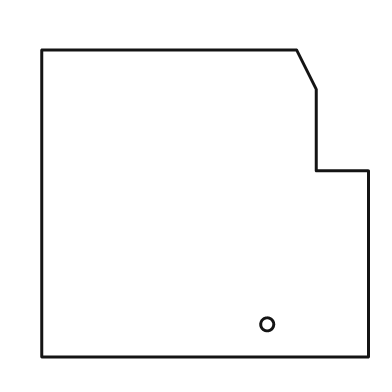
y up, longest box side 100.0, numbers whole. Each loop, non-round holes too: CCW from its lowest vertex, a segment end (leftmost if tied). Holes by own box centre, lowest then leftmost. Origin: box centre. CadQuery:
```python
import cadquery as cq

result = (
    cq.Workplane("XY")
    .moveTo(-50.0, -47.0)
    .lineTo(50.0, -47.0)
    .lineTo(50.0, 10.0)
    .lineTo(34.0, 10.0)
    .lineTo(34.0, 35.0)
    .lineTo(28.0, 47.0)
    .lineTo(-50.0, 47.0)
    .close()
    .moveTo(19.0, -37.0)
    .circle(2.0)
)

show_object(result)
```